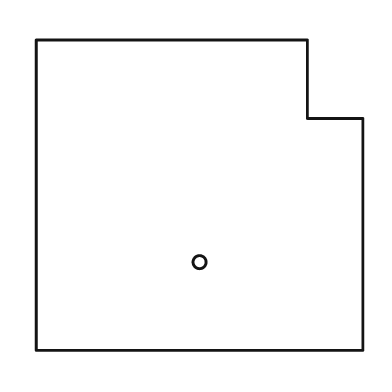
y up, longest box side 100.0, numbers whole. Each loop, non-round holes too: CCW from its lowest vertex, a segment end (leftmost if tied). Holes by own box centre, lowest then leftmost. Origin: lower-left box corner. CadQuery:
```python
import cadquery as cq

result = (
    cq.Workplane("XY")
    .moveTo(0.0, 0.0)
    .lineTo(100.0, 0.0)
    .lineTo(100.0, 71.0)
    .lineTo(83.0, 71.0)
    .lineTo(83.0, 95.0)
    .lineTo(0.0, 95.0)
    .close()
    .moveTo(50.0, 27.0)
    .circle(2.0)
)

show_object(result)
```